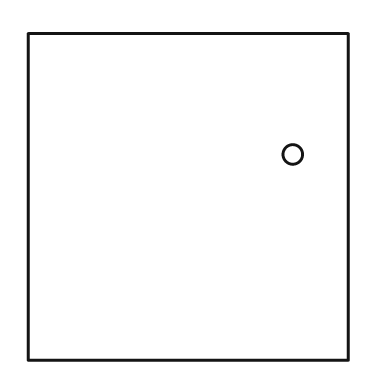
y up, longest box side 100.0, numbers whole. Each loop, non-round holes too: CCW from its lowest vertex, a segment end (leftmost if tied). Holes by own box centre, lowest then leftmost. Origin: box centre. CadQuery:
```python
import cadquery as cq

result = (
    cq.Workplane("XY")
    .moveTo(-49.0, -50.0)
    .lineTo(49.0, -50.0)
    .lineTo(49.0, 50.0)
    .lineTo(-49.0, 50.0)
    .close()
    .moveTo(32.0, 13.0)
    .circle(3.0)
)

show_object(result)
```